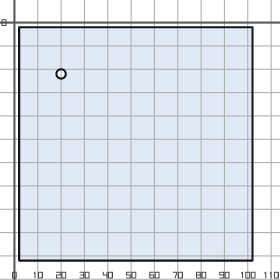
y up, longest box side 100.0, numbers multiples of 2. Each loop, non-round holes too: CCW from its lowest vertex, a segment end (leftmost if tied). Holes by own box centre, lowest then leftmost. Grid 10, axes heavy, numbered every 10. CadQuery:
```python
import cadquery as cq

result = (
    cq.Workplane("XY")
    .moveTo(2.0, -102.0)
    .lineTo(102.0, -102.0)
    .lineTo(102.0, -2.0)
    .lineTo(2.0, -2.0)
    .close()
    .moveTo(20.0, -22.0)
    .circle(2.0)
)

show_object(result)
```